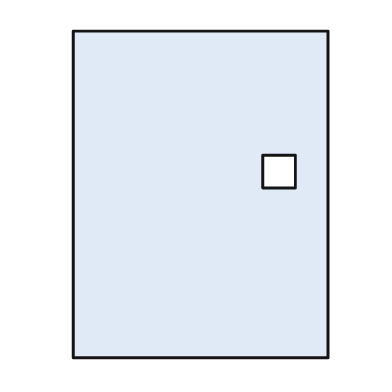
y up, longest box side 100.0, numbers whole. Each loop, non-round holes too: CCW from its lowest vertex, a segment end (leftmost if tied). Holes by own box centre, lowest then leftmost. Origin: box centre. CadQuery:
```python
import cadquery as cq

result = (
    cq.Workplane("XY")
    .moveTo(-39.0, -50.0)
    .lineTo(39.0, -50.0)
    .lineTo(39.0, 50.0)
    .lineTo(-39.0, 50.0)
    .close()
    .moveTo(19.0, 2.0)
    .lineTo(29.0, 2.0)
    .lineTo(29.0, 12.0)
    .lineTo(19.0, 12.0)
    .close()
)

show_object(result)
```